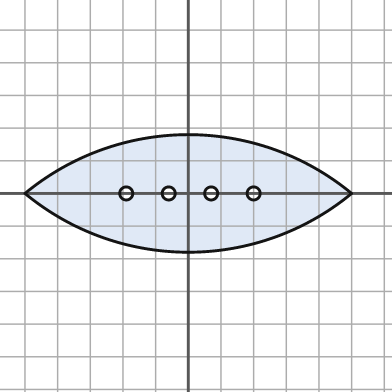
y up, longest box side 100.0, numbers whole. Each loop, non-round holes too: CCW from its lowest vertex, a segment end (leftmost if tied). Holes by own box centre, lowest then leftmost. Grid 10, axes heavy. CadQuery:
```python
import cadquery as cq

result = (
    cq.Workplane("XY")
    .moveTo(-50.0, 0.0)
    .threePointArc((0.0, -18.0), (50.0, 0.0))
    .threePointArc((0.0, 18.0), (-50.0, 0.0))
    .close()
    .moveTo(-19.0, 0.0)
    .circle(2.0)
    .moveTo(-6.0, 0.0)
    .circle(2.0)
    .moveTo(7.0, 0.0)
    .circle(2.0)
    .moveTo(20.0, 0.0)
    .circle(2.0)
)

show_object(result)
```